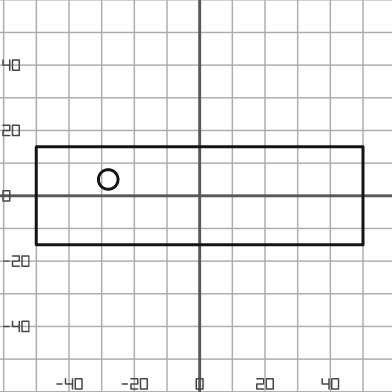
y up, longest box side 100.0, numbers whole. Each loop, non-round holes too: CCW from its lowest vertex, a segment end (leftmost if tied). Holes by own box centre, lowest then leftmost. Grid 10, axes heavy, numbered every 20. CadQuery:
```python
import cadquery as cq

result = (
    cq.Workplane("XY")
    .moveTo(-50.0, -15.0)
    .lineTo(50.0, -15.0)
    .lineTo(50.0, 15.0)
    .lineTo(-50.0, 15.0)
    .close()
    .moveTo(-28.0, 5.0)
    .circle(3.0)
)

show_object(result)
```